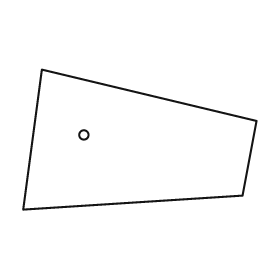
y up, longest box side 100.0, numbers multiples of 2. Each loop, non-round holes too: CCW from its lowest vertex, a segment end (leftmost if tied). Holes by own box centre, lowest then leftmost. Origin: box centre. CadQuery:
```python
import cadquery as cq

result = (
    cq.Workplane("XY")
    .moveTo(-50.0, -30.0)
    .lineTo(44.0, -24.0)
    .lineTo(50.0, 8.0)
    .lineTo(-42.0, 30.0)
    .close()
    .moveTo(-24.0, 2.0)
    .circle(2.0)
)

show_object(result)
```